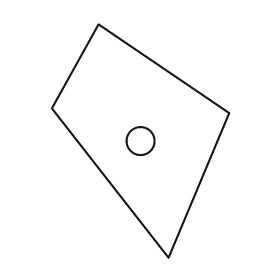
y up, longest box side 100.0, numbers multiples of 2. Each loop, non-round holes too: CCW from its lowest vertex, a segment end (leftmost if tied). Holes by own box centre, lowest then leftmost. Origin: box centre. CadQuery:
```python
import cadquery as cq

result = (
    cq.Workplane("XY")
    .moveTo(12.0, -50.0)
    .lineTo(38.0, 12.0)
    .lineTo(-18.0, 50.0)
    .lineTo(-38.0, 14.0)
    .close()
    .moveTo(0.0, 0.0)
    .circle(6.0)
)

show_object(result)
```